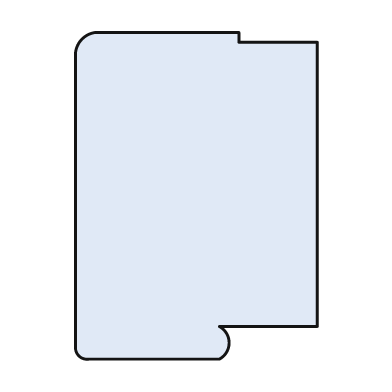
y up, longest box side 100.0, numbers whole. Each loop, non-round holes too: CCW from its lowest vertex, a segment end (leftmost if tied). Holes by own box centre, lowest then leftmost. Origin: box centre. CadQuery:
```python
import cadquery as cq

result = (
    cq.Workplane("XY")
    .moveTo(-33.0, -50.0)
    .lineTo(7.0, -50.0)
    .threePointArc((10.0, -45.0), (7.0, -40.0))
    .lineTo(37.0, -40.0)
    .lineTo(37.0, 47.0)
    .lineTo(13.0, 47.0)
    .lineTo(13.0, 50.0)
    .lineTo(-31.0, 50.0)
    .threePointArc((-35.0, 48.0), (-37.0, 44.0))
    .lineTo(-37.0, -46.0)
    .threePointArc((-36.0, -49.0), (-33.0, -50.0))
    .close()
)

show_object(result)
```